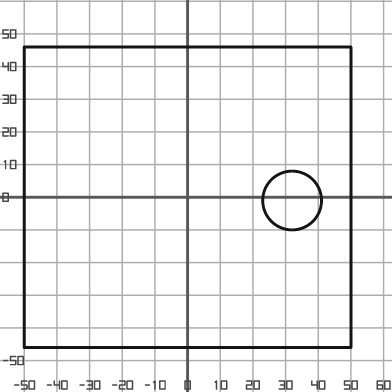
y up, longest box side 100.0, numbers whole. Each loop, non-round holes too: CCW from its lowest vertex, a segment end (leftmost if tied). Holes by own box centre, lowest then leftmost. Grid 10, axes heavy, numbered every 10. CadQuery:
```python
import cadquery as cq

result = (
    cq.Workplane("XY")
    .moveTo(-50.0, -46.0)
    .lineTo(50.0, -46.0)
    .lineTo(50.0, 46.0)
    .lineTo(-50.0, 46.0)
    .close()
    .moveTo(32.0, -1.0)
    .circle(9.0)
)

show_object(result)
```